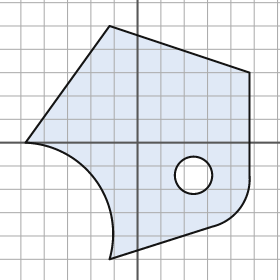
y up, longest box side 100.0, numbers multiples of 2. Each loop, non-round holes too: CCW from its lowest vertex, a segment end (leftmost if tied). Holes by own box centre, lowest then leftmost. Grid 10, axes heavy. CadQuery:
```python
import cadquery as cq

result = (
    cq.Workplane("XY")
    .moveTo(-12.0, -50.0)
    .lineTo(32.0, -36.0)
    .threePointArc((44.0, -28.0), (48.0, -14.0))
    .lineTo(48.0, 30.0)
    .lineTo(-12.0, 50.0)
    .lineTo(-48.0, 0.0)
    .threePointArc((-18.0, -16.0), (-12.0, -50.0))
    .close()
    .moveTo(24.0, -14.0)
    .circle(8.0)
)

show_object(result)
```